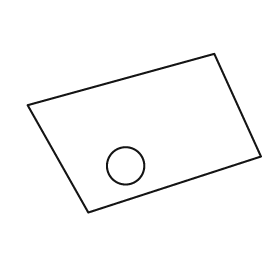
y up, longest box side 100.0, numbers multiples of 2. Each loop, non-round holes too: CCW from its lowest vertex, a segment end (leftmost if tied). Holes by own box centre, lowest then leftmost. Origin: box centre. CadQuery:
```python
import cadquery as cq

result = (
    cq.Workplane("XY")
    .moveTo(-24.0, -34.0)
    .lineTo(50.0, -10.0)
    .lineTo(30.0, 34.0)
    .lineTo(-50.0, 12.0)
    .close()
    .moveTo(-8.0, -14.0)
    .circle(8.0)
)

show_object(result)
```